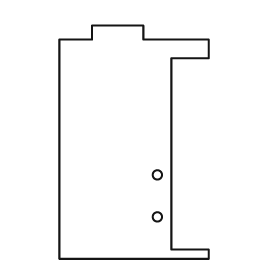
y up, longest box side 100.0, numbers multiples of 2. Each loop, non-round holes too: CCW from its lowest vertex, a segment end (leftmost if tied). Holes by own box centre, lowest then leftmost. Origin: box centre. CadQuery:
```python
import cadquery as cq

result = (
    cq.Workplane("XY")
    .moveTo(-32.0, -50.0)
    .lineTo(32.0, -50.0)
    .lineTo(32.0, -46.0)
    .lineTo(16.0, -46.0)
    .lineTo(16.0, 36.0)
    .lineTo(32.0, 36.0)
    .lineTo(32.0, 44.0)
    .lineTo(4.0, 44.0)
    .lineTo(4.0, 50.0)
    .lineTo(-18.0, 50.0)
    .lineTo(-18.0, 44.0)
    .lineTo(-32.0, 44.0)
    .close()
    .moveTo(10.0, -32.0)
    .circle(2.0)
    .moveTo(10.0, -14.0)
    .circle(2.0)
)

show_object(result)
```